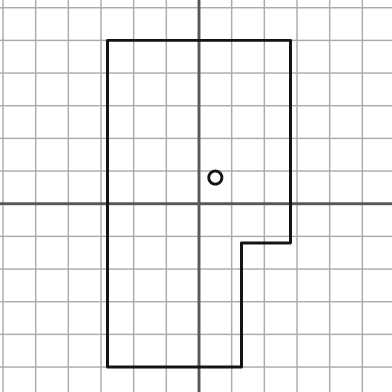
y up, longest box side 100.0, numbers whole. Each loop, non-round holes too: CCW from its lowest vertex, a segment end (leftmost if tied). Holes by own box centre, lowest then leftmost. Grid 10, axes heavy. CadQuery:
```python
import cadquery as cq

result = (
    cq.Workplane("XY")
    .moveTo(-28.0, -50.0)
    .lineTo(13.0, -50.0)
    .lineTo(13.0, -12.0)
    .lineTo(28.0, -12.0)
    .lineTo(28.0, 50.0)
    .lineTo(-28.0, 50.0)
    .close()
    .moveTo(5.0, 8.0)
    .circle(2.0)
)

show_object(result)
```